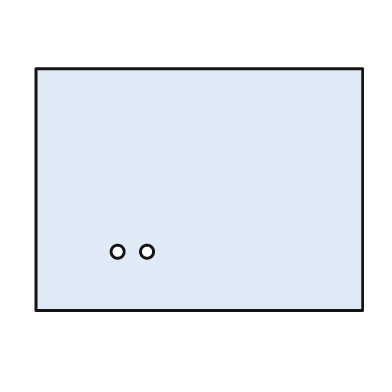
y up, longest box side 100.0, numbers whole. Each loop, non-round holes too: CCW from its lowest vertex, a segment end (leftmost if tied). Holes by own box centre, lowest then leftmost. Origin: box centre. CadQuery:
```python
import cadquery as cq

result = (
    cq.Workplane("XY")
    .moveTo(-50.0, -37.0)
    .lineTo(50.0, -37.0)
    .lineTo(50.0, 37.0)
    .lineTo(-50.0, 37.0)
    .close()
    .moveTo(-25.0, -19.0)
    .circle(2.0)
    .moveTo(-16.0, -19.0)
    .circle(2.0)
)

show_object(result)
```